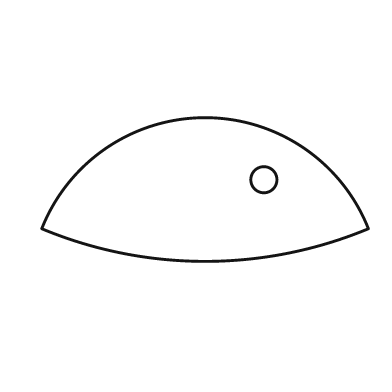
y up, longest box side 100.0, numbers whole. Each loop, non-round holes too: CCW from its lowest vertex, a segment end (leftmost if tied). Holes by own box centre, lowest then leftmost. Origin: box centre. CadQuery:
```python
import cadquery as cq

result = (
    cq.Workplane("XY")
    .moveTo(-50.0, -12.0)
    .threePointArc((0.0, -22.0), (50.0, -12.0))
    .threePointArc((0.0, 22.0), (-50.0, -12.0))
    .close()
    .moveTo(18.0, 3.0)
    .circle(4.0)
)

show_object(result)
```